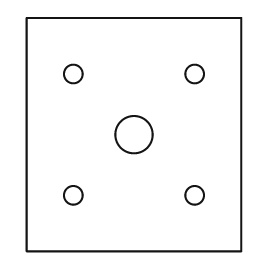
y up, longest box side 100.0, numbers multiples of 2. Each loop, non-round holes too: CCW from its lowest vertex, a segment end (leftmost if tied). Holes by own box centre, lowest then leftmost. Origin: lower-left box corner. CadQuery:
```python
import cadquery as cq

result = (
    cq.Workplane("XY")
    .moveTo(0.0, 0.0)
    .lineTo(92.0, 0.0)
    .lineTo(92.0, 100.0)
    .lineTo(0.0, 100.0)
    .close()
    .moveTo(20.0, 24.0)
    .circle(4.0)
    .moveTo(72.0, 24.0)
    .circle(4.0)
    .moveTo(46.0, 50.0)
    .circle(8.0)
    .moveTo(20.0, 76.0)
    .circle(4.0)
    .moveTo(72.0, 76.0)
    .circle(4.0)
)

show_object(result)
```